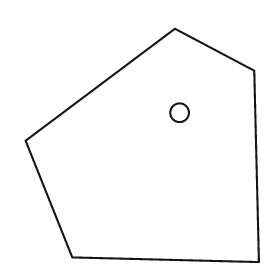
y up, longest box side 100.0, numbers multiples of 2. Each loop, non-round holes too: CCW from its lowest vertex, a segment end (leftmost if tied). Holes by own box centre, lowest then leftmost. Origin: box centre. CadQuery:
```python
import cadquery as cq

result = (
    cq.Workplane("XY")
    .moveTo(50.0, -50.0)
    .lineTo(48.0, 32.0)
    .lineTo(14.0, 50.0)
    .lineTo(-50.0, 2.0)
    .lineTo(-30.0, -48.0)
    .close()
    .moveTo(16.0, 14.0)
    .circle(4.0)
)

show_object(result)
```